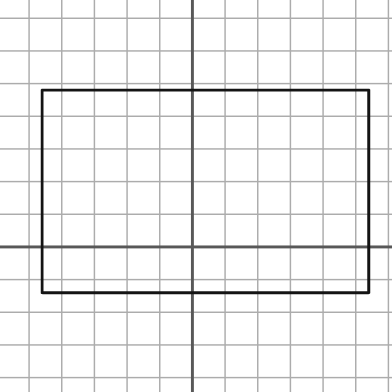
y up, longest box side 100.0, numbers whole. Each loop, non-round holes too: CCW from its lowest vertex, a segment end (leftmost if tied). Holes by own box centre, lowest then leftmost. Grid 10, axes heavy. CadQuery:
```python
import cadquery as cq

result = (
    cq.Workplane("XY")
    .moveTo(-46.0, -14.0)
    .lineTo(54.0, -14.0)
    .lineTo(54.0, 48.0)
    .lineTo(-46.0, 48.0)
    .close()
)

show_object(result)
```